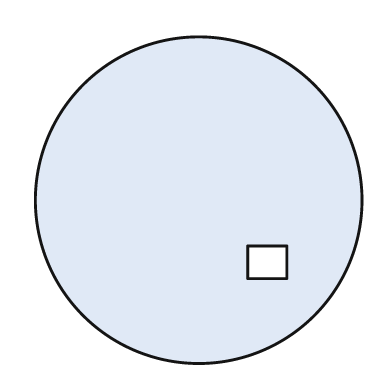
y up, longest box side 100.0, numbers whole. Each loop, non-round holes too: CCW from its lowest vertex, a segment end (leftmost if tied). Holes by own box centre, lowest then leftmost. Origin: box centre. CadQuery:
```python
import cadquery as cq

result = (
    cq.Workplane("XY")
    .moveTo(0.0, 0.0)
    .circle(50.0)
    .moveTo(15.0, -24.0)
    .lineTo(27.0, -24.0)
    .lineTo(27.0, -14.0)
    .lineTo(15.0, -14.0)
    .close()
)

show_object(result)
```